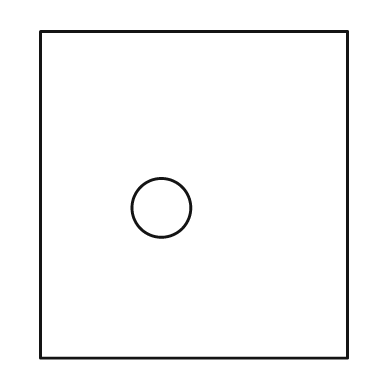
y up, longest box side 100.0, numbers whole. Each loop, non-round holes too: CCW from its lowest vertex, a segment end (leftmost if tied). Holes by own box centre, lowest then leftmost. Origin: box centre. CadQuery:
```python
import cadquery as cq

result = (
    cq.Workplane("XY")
    .moveTo(-47.0, -50.0)
    .lineTo(47.0, -50.0)
    .lineTo(47.0, 50.0)
    .lineTo(-47.0, 50.0)
    .close()
    .moveTo(-10.0, -4.0)
    .circle(9.0)
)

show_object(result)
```